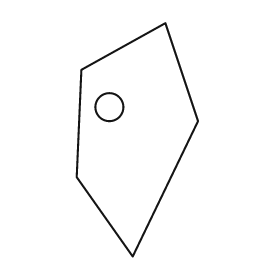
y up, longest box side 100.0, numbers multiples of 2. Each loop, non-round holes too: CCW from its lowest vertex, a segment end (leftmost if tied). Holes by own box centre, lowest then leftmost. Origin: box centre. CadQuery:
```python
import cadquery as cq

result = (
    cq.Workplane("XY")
    .moveTo(-2.0, -50.0)
    .lineTo(26.0, 8.0)
    .lineTo(12.0, 50.0)
    .lineTo(-24.0, 30.0)
    .lineTo(-26.0, -16.0)
    .close()
    .moveTo(-12.0, 14.0)
    .circle(6.0)
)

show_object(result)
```